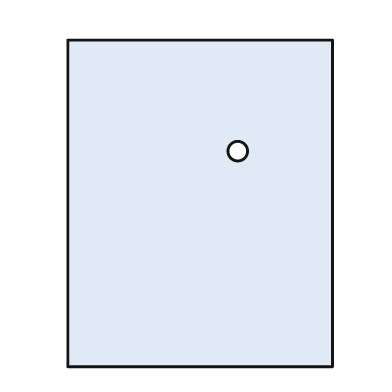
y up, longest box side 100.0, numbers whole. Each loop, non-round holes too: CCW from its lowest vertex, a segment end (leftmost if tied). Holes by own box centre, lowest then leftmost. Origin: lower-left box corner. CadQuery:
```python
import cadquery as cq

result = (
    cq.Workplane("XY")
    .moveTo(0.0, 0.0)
    .lineTo(81.0, 0.0)
    .lineTo(81.0, 100.0)
    .lineTo(0.0, 100.0)
    .close()
    .moveTo(52.0, 66.0)
    .circle(3.0)
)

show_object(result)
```